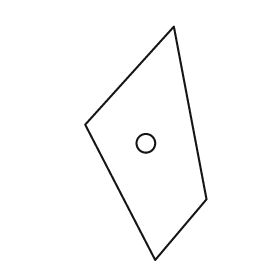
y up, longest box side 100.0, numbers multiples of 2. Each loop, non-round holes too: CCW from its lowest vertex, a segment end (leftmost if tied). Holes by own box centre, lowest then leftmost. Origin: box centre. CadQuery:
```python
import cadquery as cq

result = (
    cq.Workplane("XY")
    .moveTo(4.0, -50.0)
    .lineTo(26.0, -24.0)
    .lineTo(12.0, 50.0)
    .lineTo(-26.0, 8.0)
    .close()
    .moveTo(0.0, 0.0)
    .circle(4.0)
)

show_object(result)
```